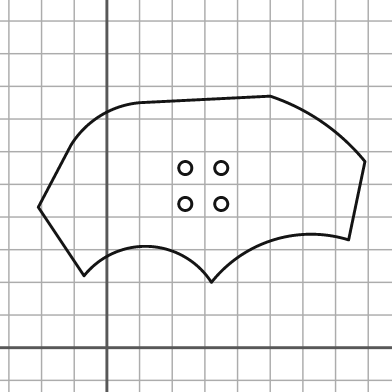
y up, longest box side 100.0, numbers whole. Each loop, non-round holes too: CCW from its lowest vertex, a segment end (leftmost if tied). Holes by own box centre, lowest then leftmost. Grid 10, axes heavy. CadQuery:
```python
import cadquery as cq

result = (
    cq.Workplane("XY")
    .moveTo(32.0, 20.0)
    .threePointArc((51.0, 33.0), (74.0, 33.0))
    .lineTo(79.0, 57.0)
    .threePointArc((66.0, 69.0), (50.0, 77.0))
    .lineTo(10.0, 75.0)
    .threePointArc((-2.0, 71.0), (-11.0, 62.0))
    .lineTo(-21.0, 43.0)
    .lineTo(-7.0, 22.0)
    .threePointArc((13.0, 31.0), (32.0, 20.0))
    .close()
    .moveTo(24.0, 44.0)
    .circle(2.0)
    .moveTo(35.0, 44.0)
    .circle(2.0)
    .moveTo(24.0, 55.0)
    .circle(2.0)
    .moveTo(35.0, 55.0)
    .circle(2.0)
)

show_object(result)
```